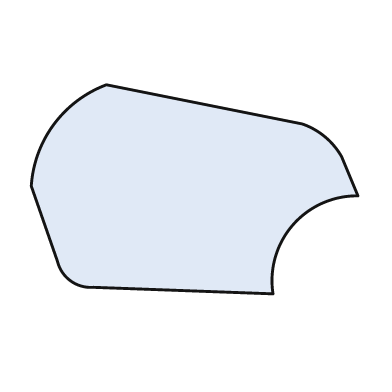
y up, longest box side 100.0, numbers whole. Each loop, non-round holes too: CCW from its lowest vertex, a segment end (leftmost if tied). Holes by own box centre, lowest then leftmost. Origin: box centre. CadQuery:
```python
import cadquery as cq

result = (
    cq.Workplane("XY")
    .moveTo(24.0, -32.0)
    .threePointArc((30.0, -11.0), (50.0, -2.0))
    .lineTo(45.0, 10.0)
    .threePointArc((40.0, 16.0), (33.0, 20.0))
    .lineTo(-27.0, 32.0)
    .threePointArc((-43.0, 20.0), (-50.0, 1.0))
    .lineTo(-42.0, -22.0)
    .threePointArc((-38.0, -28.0), (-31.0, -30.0))
    .close()
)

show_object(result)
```